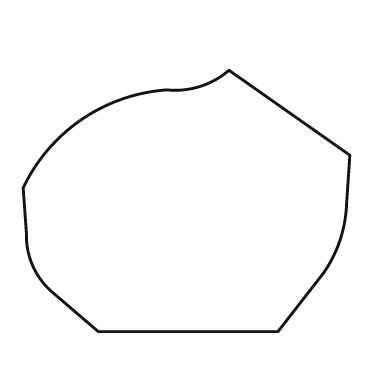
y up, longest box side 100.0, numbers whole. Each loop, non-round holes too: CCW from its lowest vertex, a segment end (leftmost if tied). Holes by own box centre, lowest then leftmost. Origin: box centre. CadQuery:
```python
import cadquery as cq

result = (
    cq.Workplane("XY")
    .moveTo(-27.0, -40.0)
    .lineTo(28.0, -40.0)
    .lineTo(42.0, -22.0)
    .threePointArc((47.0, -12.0), (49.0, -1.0))
    .lineTo(50.0, 14.0)
    .lineTo(13.0, 40.0)
    .threePointArc((4.0, 35.0), (-6.0, 34.0))
    .threePointArc((-32.0, 25.0), (-50.0, 4.0))
    .lineTo(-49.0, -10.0)
    .threePointArc((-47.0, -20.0), (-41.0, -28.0))
    .close()
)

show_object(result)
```